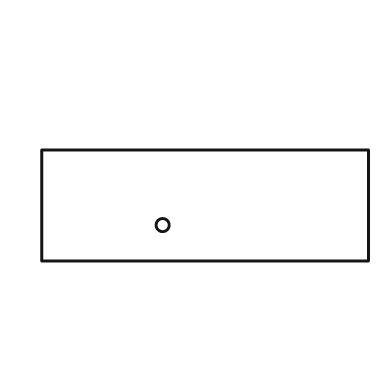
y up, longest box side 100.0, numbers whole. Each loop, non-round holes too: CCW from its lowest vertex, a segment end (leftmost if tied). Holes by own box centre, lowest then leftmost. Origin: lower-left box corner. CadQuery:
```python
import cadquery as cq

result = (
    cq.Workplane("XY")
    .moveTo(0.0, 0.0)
    .lineTo(100.0, 0.0)
    .lineTo(100.0, 34.0)
    .lineTo(0.0, 34.0)
    .close()
    .moveTo(37.0, 11.0)
    .circle(2.0)
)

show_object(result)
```